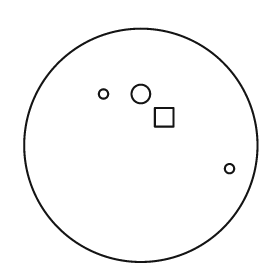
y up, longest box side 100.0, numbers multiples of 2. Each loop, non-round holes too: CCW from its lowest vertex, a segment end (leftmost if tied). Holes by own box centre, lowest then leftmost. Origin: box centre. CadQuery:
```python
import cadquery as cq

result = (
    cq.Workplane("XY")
    .moveTo(0.0, 0.0)
    .circle(50.0)
    .moveTo(38.0, -10.0)
    .circle(2.0)
    .moveTo(6.0, 8.0)
    .lineTo(14.0, 8.0)
    .lineTo(14.0, 16.0)
    .lineTo(6.0, 16.0)
    .close()
    .moveTo(-16.0, 22.0)
    .circle(2.0)
    .moveTo(0.0, 22.0)
    .circle(4.0)
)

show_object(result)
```